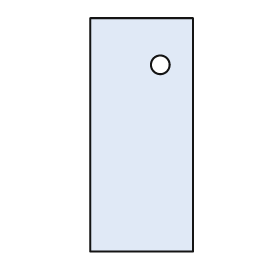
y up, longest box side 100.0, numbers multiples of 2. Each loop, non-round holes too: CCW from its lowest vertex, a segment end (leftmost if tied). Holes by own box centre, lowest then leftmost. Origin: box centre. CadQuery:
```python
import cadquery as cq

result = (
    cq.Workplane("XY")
    .moveTo(-22.0, -50.0)
    .lineTo(22.0, -50.0)
    .lineTo(22.0, 50.0)
    .lineTo(-22.0, 50.0)
    .close()
    .moveTo(8.0, 30.0)
    .circle(4.0)
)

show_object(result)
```